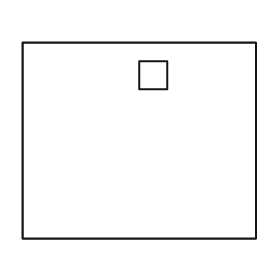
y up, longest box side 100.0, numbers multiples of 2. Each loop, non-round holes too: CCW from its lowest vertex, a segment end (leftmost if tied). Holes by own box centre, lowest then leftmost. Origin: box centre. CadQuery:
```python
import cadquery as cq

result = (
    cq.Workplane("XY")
    .moveTo(-50.0, -42.0)
    .lineTo(50.0, -42.0)
    .lineTo(50.0, 42.0)
    .lineTo(-50.0, 42.0)
    .close()
    .moveTo(0.0, 22.0)
    .lineTo(12.0, 22.0)
    .lineTo(12.0, 34.0)
    .lineTo(0.0, 34.0)
    .close()
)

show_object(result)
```